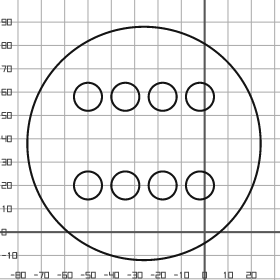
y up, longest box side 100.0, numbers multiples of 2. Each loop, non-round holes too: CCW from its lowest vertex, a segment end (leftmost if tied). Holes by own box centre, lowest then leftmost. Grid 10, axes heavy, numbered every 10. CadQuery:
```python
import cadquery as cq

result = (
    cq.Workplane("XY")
    .moveTo(-26.0, 38.0)
    .circle(50.0)
    .moveTo(-50.0, 20.0)
    .circle(6.0)
    .moveTo(-34.0, 20.0)
    .circle(6.0)
    .moveTo(-18.0, 20.0)
    .circle(6.0)
    .moveTo(-2.0, 20.0)
    .circle(6.0)
    .moveTo(-50.0, 58.0)
    .circle(6.0)
    .moveTo(-34.0, 58.0)
    .circle(6.0)
    .moveTo(-18.0, 58.0)
    .circle(6.0)
    .moveTo(-2.0, 58.0)
    .circle(6.0)
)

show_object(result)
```